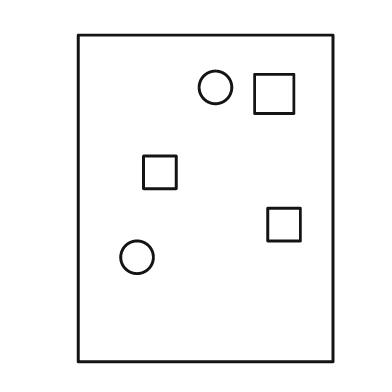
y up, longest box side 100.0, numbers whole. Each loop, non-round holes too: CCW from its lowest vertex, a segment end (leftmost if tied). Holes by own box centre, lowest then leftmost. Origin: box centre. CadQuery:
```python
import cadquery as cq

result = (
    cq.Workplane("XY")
    .moveTo(-39.0, -50.0)
    .lineTo(39.0, -50.0)
    .lineTo(39.0, 50.0)
    .lineTo(-39.0, 50.0)
    .close()
    .moveTo(-21.0, -18.0)
    .circle(5.0)
    .moveTo(19.0, -13.0)
    .lineTo(29.0, -13.0)
    .lineTo(29.0, -3.0)
    .lineTo(19.0, -3.0)
    .close()
    .moveTo(-19.0, 3.0)
    .lineTo(-9.0, 3.0)
    .lineTo(-9.0, 13.0)
    .lineTo(-19.0, 13.0)
    .close()
    .moveTo(15.0, 26.0)
    .lineTo(27.0, 26.0)
    .lineTo(27.0, 38.0)
    .lineTo(15.0, 38.0)
    .close()
    .moveTo(3.0, 34.0)
    .circle(5.0)
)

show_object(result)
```